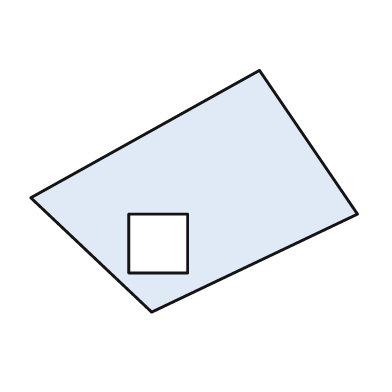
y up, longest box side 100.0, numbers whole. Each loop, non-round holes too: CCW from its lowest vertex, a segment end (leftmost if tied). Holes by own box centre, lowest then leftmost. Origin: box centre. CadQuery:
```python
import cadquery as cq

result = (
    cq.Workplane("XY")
    .moveTo(-13.0, -37.0)
    .lineTo(50.0, -7.0)
    .lineTo(20.0, 37.0)
    .lineTo(-50.0, -2.0)
    .close()
    .moveTo(-20.0, -25.0)
    .lineTo(-2.0, -25.0)
    .lineTo(-2.0, -7.0)
    .lineTo(-20.0, -7.0)
    .close()
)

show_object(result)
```